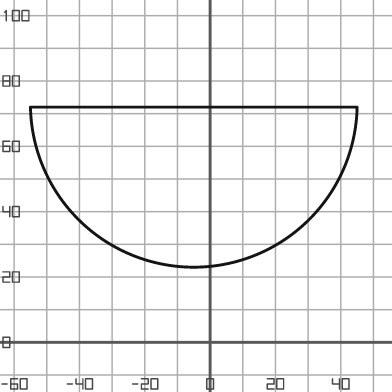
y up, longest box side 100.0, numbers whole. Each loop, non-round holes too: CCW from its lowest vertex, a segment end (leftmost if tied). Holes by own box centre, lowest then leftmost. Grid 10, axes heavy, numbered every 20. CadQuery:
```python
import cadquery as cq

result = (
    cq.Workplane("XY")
    .moveTo(-55.0, 72.0)
    .threePointArc((-5.0, 23.0), (45.0, 72.0))
    .close()
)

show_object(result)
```